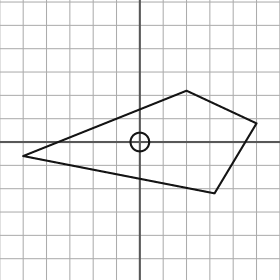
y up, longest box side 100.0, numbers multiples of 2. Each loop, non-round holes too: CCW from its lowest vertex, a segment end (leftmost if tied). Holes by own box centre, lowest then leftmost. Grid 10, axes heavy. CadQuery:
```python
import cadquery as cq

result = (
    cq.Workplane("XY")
    .moveTo(32.0, -22.0)
    .lineTo(50.0, 8.0)
    .lineTo(20.0, 22.0)
    .lineTo(-50.0, -6.0)
    .close()
    .moveTo(0.0, 0.0)
    .circle(4.0)
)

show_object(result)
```